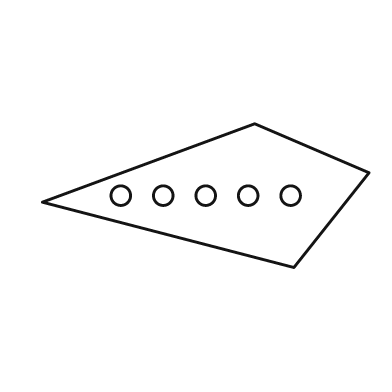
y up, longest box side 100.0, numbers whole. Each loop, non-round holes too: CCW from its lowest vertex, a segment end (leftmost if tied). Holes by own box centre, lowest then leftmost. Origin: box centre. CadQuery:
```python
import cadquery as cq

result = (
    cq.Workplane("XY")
    .moveTo(27.0, -22.0)
    .lineTo(50.0, 7.0)
    .lineTo(15.0, 22.0)
    .lineTo(-50.0, -2.0)
    .close()
    .moveTo(-26.0, 0.0)
    .circle(3.0)
    .moveTo(-13.0, 0.0)
    .circle(3.0)
    .moveTo(0.0, 0.0)
    .circle(3.0)
    .moveTo(13.0, 0.0)
    .circle(3.0)
    .moveTo(26.0, 0.0)
    .circle(3.0)
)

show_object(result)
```